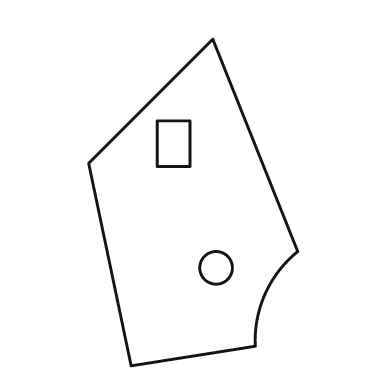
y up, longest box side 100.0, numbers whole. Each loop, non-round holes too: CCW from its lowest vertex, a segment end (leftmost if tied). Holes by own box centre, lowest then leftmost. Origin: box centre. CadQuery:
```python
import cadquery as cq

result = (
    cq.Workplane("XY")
    .moveTo(-19.0, -50.0)
    .lineTo(19.0, -44.0)
    .threePointArc((22.0, -28.0), (32.0, -15.0))
    .lineTo(6.0, 50.0)
    .lineTo(-32.0, 12.0)
    .close()
    .moveTo(7.0, -20.0)
    .circle(5.0)
    .moveTo(-11.0, 11.0)
    .lineTo(-1.0, 11.0)
    .lineTo(-1.0, 25.0)
    .lineTo(-11.0, 25.0)
    .close()
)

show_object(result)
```